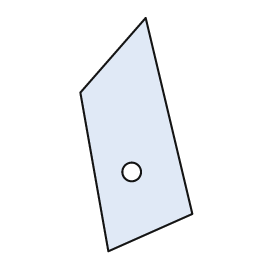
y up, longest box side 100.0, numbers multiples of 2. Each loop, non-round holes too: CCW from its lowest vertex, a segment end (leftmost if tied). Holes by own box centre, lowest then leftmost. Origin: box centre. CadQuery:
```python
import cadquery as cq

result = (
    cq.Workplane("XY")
    .moveTo(-12.0, -50.0)
    .lineTo(24.0, -34.0)
    .lineTo(4.0, 50.0)
    .lineTo(-24.0, 18.0)
    .close()
    .moveTo(-2.0, -16.0)
    .circle(4.0)
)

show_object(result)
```